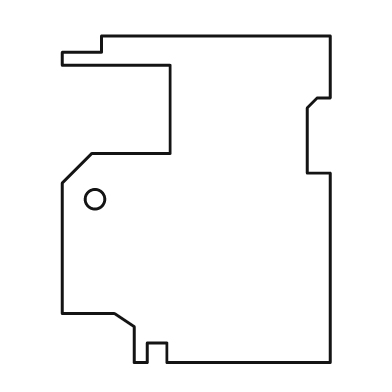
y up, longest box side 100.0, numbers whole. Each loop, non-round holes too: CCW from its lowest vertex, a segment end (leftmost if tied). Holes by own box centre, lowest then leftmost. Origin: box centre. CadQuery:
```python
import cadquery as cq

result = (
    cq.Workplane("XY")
    .moveTo(-19.0, -50.0)
    .lineTo(-15.0, -50.0)
    .lineTo(-15.0, -44.0)
    .lineTo(-9.0, -44.0)
    .lineTo(-9.0, -50.0)
    .lineTo(41.0, -50.0)
    .lineTo(41.0, 8.0)
    .lineTo(34.0, 8.0)
    .lineTo(34.0, 28.0)
    .lineTo(37.0, 31.0)
    .lineTo(41.0, 31.0)
    .lineTo(41.0, 50.0)
    .lineTo(-29.0, 50.0)
    .lineTo(-29.0, 45.0)
    .lineTo(-41.0, 45.0)
    .lineTo(-41.0, 41.0)
    .lineTo(-8.0, 41.0)
    .lineTo(-8.0, 14.0)
    .lineTo(-32.0, 14.0)
    .lineTo(-41.0, 5.0)
    .lineTo(-41.0, -35.0)
    .lineTo(-25.0, -35.0)
    .lineTo(-19.0, -39.0)
    .close()
    .moveTo(-31.0, 0.0)
    .circle(3.0)
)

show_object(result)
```